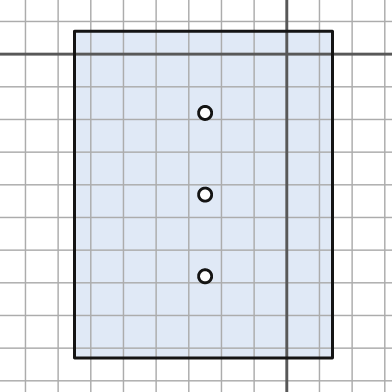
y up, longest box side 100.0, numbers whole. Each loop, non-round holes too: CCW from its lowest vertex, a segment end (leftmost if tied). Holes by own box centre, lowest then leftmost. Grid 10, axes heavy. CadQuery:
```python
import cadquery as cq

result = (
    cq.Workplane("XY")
    .moveTo(-65.0, -93.0)
    .lineTo(14.0, -93.0)
    .lineTo(14.0, 7.0)
    .lineTo(-65.0, 7.0)
    .close()
    .moveTo(-25.0, -68.0)
    .circle(2.0)
    .moveTo(-25.0, -43.0)
    .circle(2.0)
    .moveTo(-25.0, -18.0)
    .circle(2.0)
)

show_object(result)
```